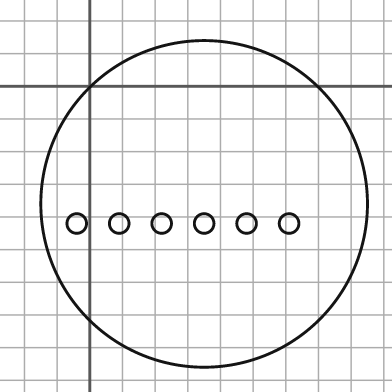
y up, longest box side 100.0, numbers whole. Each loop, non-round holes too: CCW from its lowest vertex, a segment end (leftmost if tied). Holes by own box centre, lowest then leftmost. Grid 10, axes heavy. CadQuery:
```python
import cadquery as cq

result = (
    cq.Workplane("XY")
    .moveTo(35.0, -36.0)
    .circle(50.0)
    .moveTo(-4.0, -42.0)
    .circle(3.0)
    .moveTo(9.0, -42.0)
    .circle(3.0)
    .moveTo(22.0, -42.0)
    .circle(3.0)
    .moveTo(35.0, -42.0)
    .circle(3.0)
    .moveTo(48.0, -42.0)
    .circle(3.0)
    .moveTo(61.0, -42.0)
    .circle(3.0)
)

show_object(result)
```